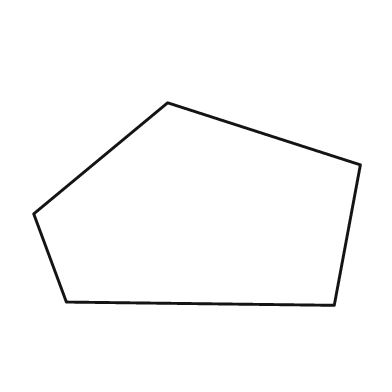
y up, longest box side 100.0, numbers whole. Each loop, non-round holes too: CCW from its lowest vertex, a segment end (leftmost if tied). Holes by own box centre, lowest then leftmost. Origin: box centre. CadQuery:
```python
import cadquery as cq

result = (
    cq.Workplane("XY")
    .moveTo(42.0, -31.0)
    .lineTo(50.0, 12.0)
    .lineTo(-9.0, 31.0)
    .lineTo(-50.0, -3.0)
    .lineTo(-40.0, -30.0)
    .close()
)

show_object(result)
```